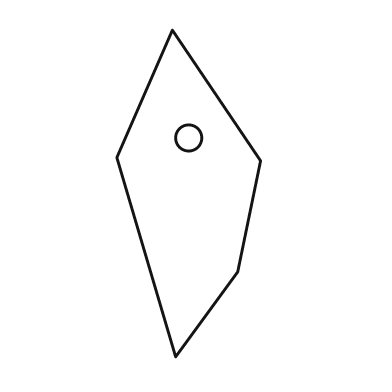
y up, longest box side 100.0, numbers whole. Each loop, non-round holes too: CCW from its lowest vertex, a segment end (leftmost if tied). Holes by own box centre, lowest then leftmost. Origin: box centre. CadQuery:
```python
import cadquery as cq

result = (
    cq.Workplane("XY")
    .moveTo(-4.0, -50.0)
    .lineTo(15.0, -24.0)
    .lineTo(22.0, 10.0)
    .lineTo(-5.0, 50.0)
    .lineTo(-22.0, 11.0)
    .close()
    .moveTo(0.0, 17.0)
    .circle(4.0)
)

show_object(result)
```